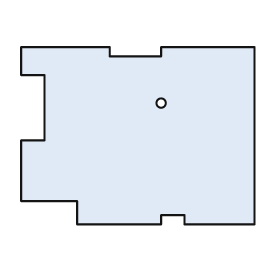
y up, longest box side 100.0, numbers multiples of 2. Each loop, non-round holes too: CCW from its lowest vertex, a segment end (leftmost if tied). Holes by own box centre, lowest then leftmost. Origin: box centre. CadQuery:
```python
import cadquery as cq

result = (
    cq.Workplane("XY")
    .moveTo(-26.0, -38.0)
    .lineTo(10.0, -38.0)
    .lineTo(10.0, -34.0)
    .lineTo(20.0, -34.0)
    .lineTo(20.0, -38.0)
    .lineTo(50.0, -38.0)
    .lineTo(50.0, 38.0)
    .lineTo(10.0, 38.0)
    .lineTo(10.0, 34.0)
    .lineTo(-12.0, 34.0)
    .lineTo(-12.0, 38.0)
    .lineTo(-50.0, 38.0)
    .lineTo(-50.0, 26.0)
    .lineTo(-40.0, 26.0)
    .lineTo(-40.0, -2.0)
    .lineTo(-50.0, -2.0)
    .lineTo(-50.0, -28.0)
    .lineTo(-26.0, -28.0)
    .close()
    .moveTo(10.0, 14.0)
    .circle(2.0)
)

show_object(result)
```